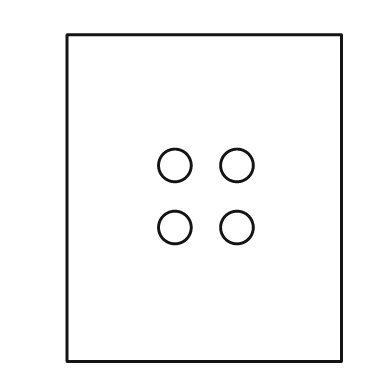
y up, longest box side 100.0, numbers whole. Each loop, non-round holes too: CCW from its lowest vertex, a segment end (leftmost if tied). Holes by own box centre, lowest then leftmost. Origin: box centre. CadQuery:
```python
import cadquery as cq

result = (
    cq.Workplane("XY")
    .moveTo(-42.0, -50.0)
    .lineTo(42.0, -50.0)
    .lineTo(42.0, 50.0)
    .lineTo(-42.0, 50.0)
    .close()
    .moveTo(-9.0, -9.0)
    .circle(5.0)
    .moveTo(10.0, -9.0)
    .circle(5.0)
    .moveTo(-9.0, 10.0)
    .circle(5.0)
    .moveTo(10.0, 10.0)
    .circle(5.0)
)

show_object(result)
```